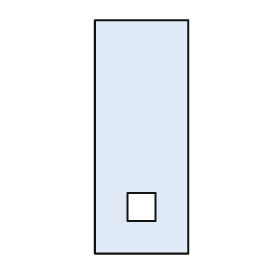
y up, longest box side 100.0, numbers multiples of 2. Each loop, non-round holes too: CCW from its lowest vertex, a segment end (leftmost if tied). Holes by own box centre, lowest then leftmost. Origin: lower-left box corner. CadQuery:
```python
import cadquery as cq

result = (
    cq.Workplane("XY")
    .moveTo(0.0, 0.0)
    .lineTo(40.0, 0.0)
    .lineTo(40.0, 100.0)
    .lineTo(0.0, 100.0)
    .close()
    .moveTo(14.0, 14.0)
    .lineTo(26.0, 14.0)
    .lineTo(26.0, 26.0)
    .lineTo(14.0, 26.0)
    .close()
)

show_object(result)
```